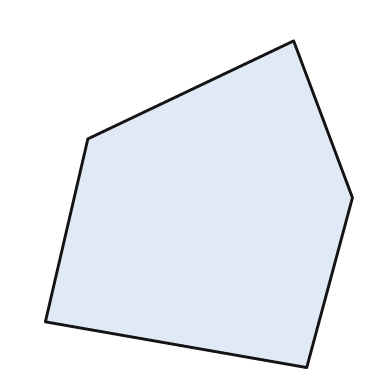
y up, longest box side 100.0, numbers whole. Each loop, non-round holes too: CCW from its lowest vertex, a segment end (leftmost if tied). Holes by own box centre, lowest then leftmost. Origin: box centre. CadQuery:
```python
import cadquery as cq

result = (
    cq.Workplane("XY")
    .moveTo(33.0, -50.0)
    .lineTo(47.0, 2.0)
    .lineTo(29.0, 50.0)
    .lineTo(-34.0, 20.0)
    .lineTo(-47.0, -36.0)
    .close()
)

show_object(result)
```